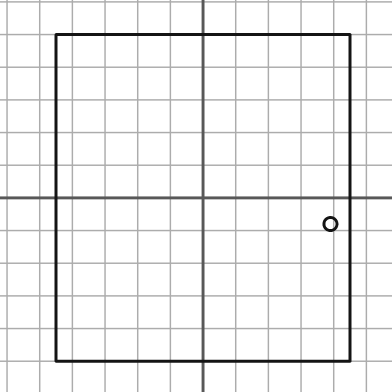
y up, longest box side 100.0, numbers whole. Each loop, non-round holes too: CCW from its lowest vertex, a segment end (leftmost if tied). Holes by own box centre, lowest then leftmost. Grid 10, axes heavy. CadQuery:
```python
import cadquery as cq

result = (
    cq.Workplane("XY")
    .moveTo(-45.0, -50.0)
    .lineTo(45.0, -50.0)
    .lineTo(45.0, 50.0)
    .lineTo(-45.0, 50.0)
    .close()
    .moveTo(39.0, -8.0)
    .circle(2.0)
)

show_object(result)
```